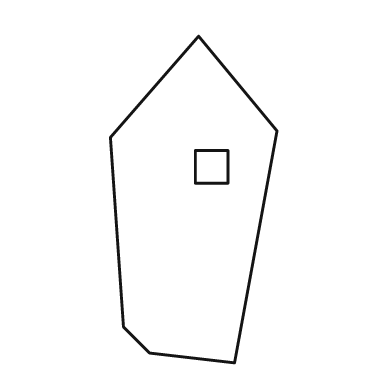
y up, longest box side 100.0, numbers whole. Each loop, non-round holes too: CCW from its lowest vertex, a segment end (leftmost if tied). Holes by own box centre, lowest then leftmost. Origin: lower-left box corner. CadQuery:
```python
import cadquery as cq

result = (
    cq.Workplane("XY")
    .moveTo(38.0, 0.0)
    .lineTo(51.0, 71.0)
    .lineTo(27.0, 100.0)
    .lineTo(0.0, 69.0)
    .lineTo(4.0, 11.0)
    .lineTo(12.0, 3.0)
    .close()
    .moveTo(26.0, 55.0)
    .lineTo(36.0, 55.0)
    .lineTo(36.0, 65.0)
    .lineTo(26.0, 65.0)
    .close()
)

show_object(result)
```